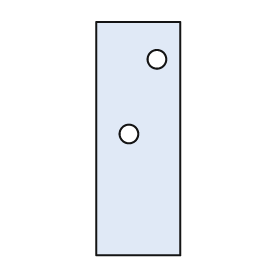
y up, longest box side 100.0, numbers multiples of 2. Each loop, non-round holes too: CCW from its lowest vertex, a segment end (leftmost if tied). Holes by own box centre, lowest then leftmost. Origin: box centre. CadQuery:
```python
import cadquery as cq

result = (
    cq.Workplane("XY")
    .moveTo(-18.0, -50.0)
    .lineTo(18.0, -50.0)
    .lineTo(18.0, 50.0)
    .lineTo(-18.0, 50.0)
    .close()
    .moveTo(-4.0, 2.0)
    .circle(4.0)
    .moveTo(8.0, 34.0)
    .circle(4.0)
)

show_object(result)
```